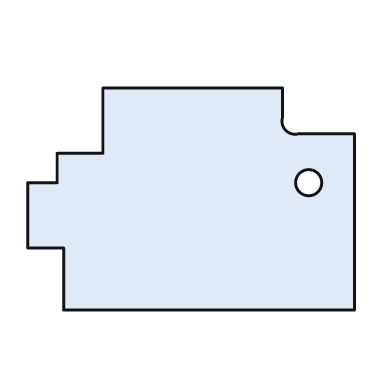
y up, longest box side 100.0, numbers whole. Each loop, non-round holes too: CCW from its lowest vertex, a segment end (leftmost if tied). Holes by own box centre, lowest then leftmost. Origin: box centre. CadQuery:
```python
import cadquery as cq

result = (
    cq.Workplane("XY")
    .moveTo(-39.0, -34.0)
    .lineTo(50.0, -34.0)
    .lineTo(50.0, 20.0)
    .lineTo(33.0, 20.0)
    .threePointArc((29.0, 21.0), (28.0, 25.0))
    .lineTo(28.0, 34.0)
    .lineTo(-27.0, 34.0)
    .lineTo(-27.0, 14.0)
    .lineTo(-41.0, 14.0)
    .lineTo(-41.0, 5.0)
    .lineTo(-50.0, 5.0)
    .lineTo(-50.0, -15.0)
    .lineTo(-39.0, -15.0)
    .close()
    .moveTo(36.0, 5.0)
    .circle(4.0)
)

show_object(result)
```